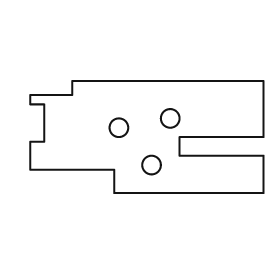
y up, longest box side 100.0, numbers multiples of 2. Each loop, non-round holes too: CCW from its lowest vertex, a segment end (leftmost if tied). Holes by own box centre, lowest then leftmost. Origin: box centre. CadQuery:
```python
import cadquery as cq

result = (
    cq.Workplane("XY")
    .moveTo(-14.0, -24.0)
    .lineTo(50.0, -24.0)
    .lineTo(50.0, -8.0)
    .lineTo(14.0, -8.0)
    .lineTo(14.0, 0.0)
    .lineTo(50.0, 0.0)
    .lineTo(50.0, 24.0)
    .lineTo(-32.0, 24.0)
    .lineTo(-32.0, 18.0)
    .lineTo(-50.0, 18.0)
    .lineTo(-50.0, 14.0)
    .lineTo(-44.0, 14.0)
    .lineTo(-44.0, -2.0)
    .lineTo(-50.0, -2.0)
    .lineTo(-50.0, -14.0)
    .lineTo(-14.0, -14.0)
    .close()
    .moveTo(2.0, -12.0)
    .circle(4.0)
    .moveTo(-12.0, 4.0)
    .circle(4.0)
    .moveTo(10.0, 8.0)
    .circle(4.0)
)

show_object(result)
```